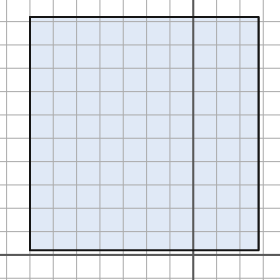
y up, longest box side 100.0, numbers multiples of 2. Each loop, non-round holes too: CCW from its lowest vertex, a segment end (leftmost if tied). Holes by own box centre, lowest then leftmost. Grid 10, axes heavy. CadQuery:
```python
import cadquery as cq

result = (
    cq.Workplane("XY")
    .moveTo(-70.0, 2.0)
    .lineTo(28.0, 2.0)
    .lineTo(28.0, 102.0)
    .lineTo(-70.0, 102.0)
    .close()
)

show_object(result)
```